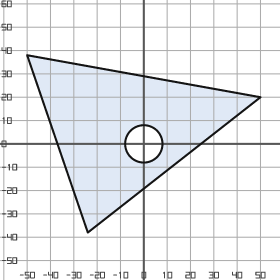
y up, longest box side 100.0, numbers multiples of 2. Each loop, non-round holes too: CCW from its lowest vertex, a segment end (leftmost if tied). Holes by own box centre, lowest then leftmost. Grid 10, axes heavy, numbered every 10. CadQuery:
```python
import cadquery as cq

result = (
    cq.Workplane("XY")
    .moveTo(-24.0, -38.0)
    .lineTo(50.0, 20.0)
    .lineTo(-50.0, 38.0)
    .close()
    .moveTo(0.0, 0.0)
    .circle(8.0)
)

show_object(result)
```